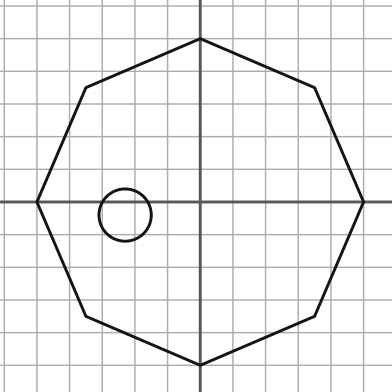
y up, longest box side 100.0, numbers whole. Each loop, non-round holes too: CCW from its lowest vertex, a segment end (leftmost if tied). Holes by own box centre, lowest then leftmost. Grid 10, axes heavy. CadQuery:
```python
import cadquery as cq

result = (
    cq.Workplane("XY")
    .moveTo(0.0, -50.0)
    .lineTo(35.0, -35.0)
    .lineTo(50.0, 0.0)
    .lineTo(35.0, 35.0)
    .lineTo(0.0, 50.0)
    .lineTo(-35.0, 35.0)
    .lineTo(-50.0, 0.0)
    .lineTo(-35.0, -35.0)
    .close()
    .moveTo(-23.0, -4.0)
    .circle(8.0)
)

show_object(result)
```